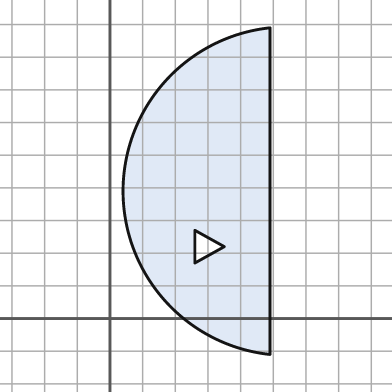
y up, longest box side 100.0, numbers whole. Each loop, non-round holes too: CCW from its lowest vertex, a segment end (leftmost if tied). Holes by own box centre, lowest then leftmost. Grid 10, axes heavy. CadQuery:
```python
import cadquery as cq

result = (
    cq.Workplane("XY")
    .moveTo(49.0, -11.0)
    .lineTo(49.0, 89.0)
    .threePointArc((4.0, 39.0), (49.0, -11.0))
    .close()
    .moveTo(26.0, 17.0)
    .lineTo(35.0, 22.0)
    .lineTo(26.0, 27.0)
    .close()
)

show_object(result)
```